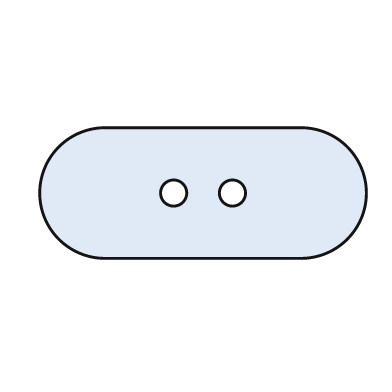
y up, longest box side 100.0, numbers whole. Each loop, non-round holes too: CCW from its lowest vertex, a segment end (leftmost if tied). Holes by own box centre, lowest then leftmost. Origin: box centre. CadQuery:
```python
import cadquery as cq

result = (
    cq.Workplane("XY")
    .moveTo(-30.0, -20.0)
    .lineTo(30.0, -20.0)
    .threePointArc((50.0, 0.0), (30.0, 20.0))
    .lineTo(-30.0, 20.0)
    .threePointArc((-50.0, 0.0), (-30.0, -20.0))
    .close()
    .moveTo(-9.0, 0.0)
    .circle(4.0)
    .moveTo(9.0, 0.0)
    .circle(4.0)
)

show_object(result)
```